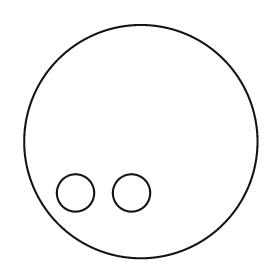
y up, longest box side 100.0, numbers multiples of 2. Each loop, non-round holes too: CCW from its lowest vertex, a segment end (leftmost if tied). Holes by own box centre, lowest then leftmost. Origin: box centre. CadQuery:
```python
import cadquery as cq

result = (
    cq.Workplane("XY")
    .moveTo(0.0, 0.0)
    .circle(50.0)
    .moveTo(-28.0, -22.0)
    .circle(8.0)
    .moveTo(-4.0, -22.0)
    .circle(8.0)
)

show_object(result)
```